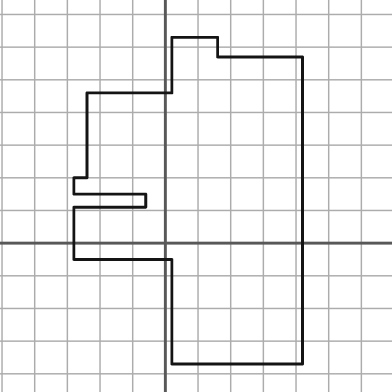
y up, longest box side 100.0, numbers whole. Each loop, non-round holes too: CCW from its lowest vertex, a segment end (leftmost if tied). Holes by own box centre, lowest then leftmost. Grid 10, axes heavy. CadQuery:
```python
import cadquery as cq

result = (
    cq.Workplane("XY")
    .moveTo(2.0, -37.0)
    .lineTo(42.0, -37.0)
    .lineTo(42.0, 57.0)
    .lineTo(16.0, 57.0)
    .lineTo(16.0, 63.0)
    .lineTo(2.0, 63.0)
    .lineTo(2.0, 46.0)
    .lineTo(-24.0, 46.0)
    .lineTo(-24.0, 20.0)
    .lineTo(-28.0, 20.0)
    .lineTo(-28.0, 15.0)
    .lineTo(-6.0, 15.0)
    .lineTo(-6.0, 11.0)
    .lineTo(-28.0, 11.0)
    .lineTo(-28.0, -5.0)
    .lineTo(2.0, -5.0)
    .close()
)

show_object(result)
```